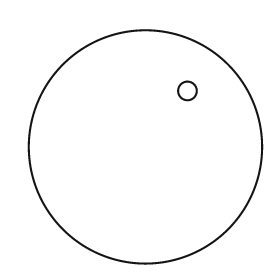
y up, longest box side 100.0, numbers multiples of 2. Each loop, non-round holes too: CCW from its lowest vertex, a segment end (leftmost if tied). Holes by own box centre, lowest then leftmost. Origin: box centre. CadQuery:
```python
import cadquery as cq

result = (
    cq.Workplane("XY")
    .moveTo(0.0, 0.0)
    .circle(50.0)
    .moveTo(18.0, 24.0)
    .circle(4.0)
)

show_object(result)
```